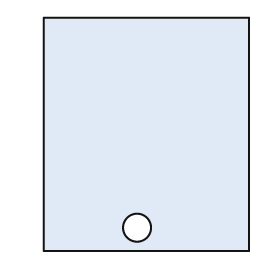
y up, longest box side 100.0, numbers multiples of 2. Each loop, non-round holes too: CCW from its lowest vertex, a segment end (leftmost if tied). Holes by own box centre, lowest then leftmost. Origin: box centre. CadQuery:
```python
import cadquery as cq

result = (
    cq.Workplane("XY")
    .moveTo(-44.0, -50.0)
    .lineTo(44.0, -50.0)
    .lineTo(44.0, 50.0)
    .lineTo(-44.0, 50.0)
    .close()
    .moveTo(-4.0, -40.0)
    .circle(6.0)
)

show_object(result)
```